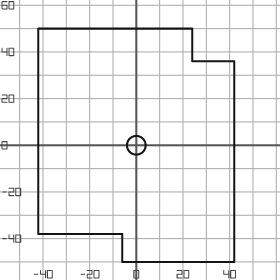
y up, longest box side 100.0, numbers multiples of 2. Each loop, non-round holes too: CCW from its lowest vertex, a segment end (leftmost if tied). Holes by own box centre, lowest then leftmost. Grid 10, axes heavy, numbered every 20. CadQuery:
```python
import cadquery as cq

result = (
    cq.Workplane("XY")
    .moveTo(-6.0, -50.0)
    .lineTo(42.0, -50.0)
    .lineTo(42.0, 36.0)
    .lineTo(24.0, 36.0)
    .lineTo(24.0, 50.0)
    .lineTo(-42.0, 50.0)
    .lineTo(-42.0, -38.0)
    .lineTo(-6.0, -38.0)
    .close()
    .moveTo(0.0, 0.0)
    .circle(4.0)
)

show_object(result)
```